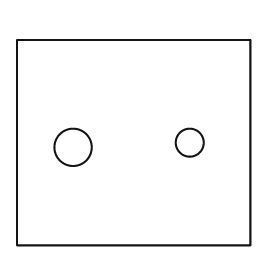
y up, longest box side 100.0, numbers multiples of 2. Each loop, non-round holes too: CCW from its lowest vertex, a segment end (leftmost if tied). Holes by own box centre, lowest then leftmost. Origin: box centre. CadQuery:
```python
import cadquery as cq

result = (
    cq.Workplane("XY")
    .moveTo(-50.0, -44.0)
    .lineTo(50.0, -44.0)
    .lineTo(50.0, 44.0)
    .lineTo(-50.0, 44.0)
    .close()
    .moveTo(-26.0, -2.0)
    .circle(8.0)
    .moveTo(24.0, 0.0)
    .circle(6.0)
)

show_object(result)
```